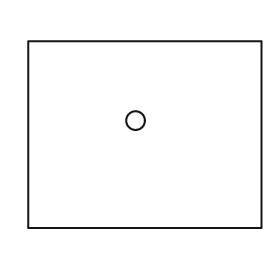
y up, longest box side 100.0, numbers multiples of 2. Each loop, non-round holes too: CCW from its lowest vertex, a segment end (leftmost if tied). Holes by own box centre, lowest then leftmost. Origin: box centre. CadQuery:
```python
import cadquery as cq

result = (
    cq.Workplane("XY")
    .moveTo(-50.0, -40.0)
    .lineTo(50.0, -40.0)
    .lineTo(50.0, 40.0)
    .lineTo(-50.0, 40.0)
    .close()
    .moveTo(-4.0, 6.0)
    .circle(4.0)
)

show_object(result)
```